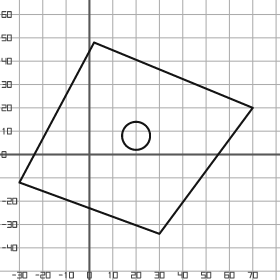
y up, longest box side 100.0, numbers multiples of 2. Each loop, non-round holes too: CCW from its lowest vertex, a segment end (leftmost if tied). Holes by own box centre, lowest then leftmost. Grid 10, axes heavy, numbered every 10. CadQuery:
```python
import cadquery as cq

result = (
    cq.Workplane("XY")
    .moveTo(30.0, -34.0)
    .lineTo(70.0, 20.0)
    .lineTo(2.0, 48.0)
    .lineTo(-30.0, -12.0)
    .close()
    .moveTo(20.0, 8.0)
    .circle(6.0)
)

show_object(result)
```